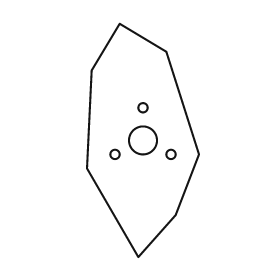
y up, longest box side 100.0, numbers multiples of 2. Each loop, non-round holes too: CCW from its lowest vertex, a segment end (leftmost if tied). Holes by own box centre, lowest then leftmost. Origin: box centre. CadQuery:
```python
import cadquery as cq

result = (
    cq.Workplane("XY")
    .moveTo(-2.0, -50.0)
    .lineTo(14.0, -32.0)
    .lineTo(24.0, -6.0)
    .lineTo(10.0, 38.0)
    .lineTo(-10.0, 50.0)
    .lineTo(-22.0, 30.0)
    .lineTo(-24.0, -12.0)
    .close()
    .moveTo(-12.0, -6.0)
    .circle(2.0)
    .moveTo(12.0, -6.0)
    .circle(2.0)
    .moveTo(0.0, 0.0)
    .circle(6.0)
    .moveTo(0.0, 14.0)
    .circle(2.0)
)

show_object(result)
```